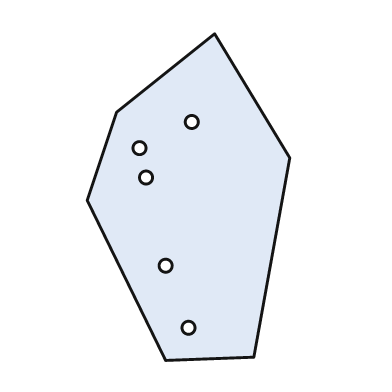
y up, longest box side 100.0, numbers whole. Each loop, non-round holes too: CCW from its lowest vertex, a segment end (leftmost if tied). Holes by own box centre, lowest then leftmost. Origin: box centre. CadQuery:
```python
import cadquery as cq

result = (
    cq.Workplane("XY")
    .moveTo(-7.0, -50.0)
    .lineTo(20.0, -49.0)
    .lineTo(31.0, 12.0)
    .lineTo(8.0, 50.0)
    .lineTo(-22.0, 26.0)
    .lineTo(-31.0, -1.0)
    .close()
    .moveTo(0.0, -40.0)
    .circle(2.0)
    .moveTo(-7.0, -21.0)
    .circle(2.0)
    .moveTo(-13.0, 6.0)
    .circle(2.0)
    .moveTo(-15.0, 15.0)
    .circle(2.0)
    .moveTo(1.0, 23.0)
    .circle(2.0)
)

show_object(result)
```